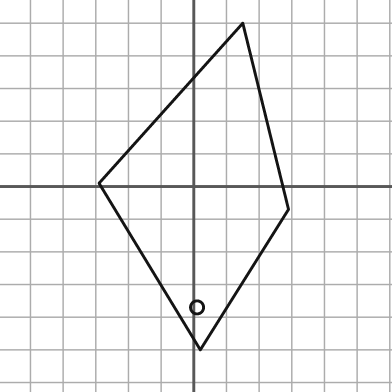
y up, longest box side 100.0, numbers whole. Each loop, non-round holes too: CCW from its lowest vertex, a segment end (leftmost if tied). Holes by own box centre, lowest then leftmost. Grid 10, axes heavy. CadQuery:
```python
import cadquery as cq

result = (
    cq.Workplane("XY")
    .moveTo(2.0, -50.0)
    .lineTo(29.0, -7.0)
    .lineTo(15.0, 50.0)
    .lineTo(-29.0, 1.0)
    .close()
    .moveTo(1.0, -37.0)
    .circle(2.0)
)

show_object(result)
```